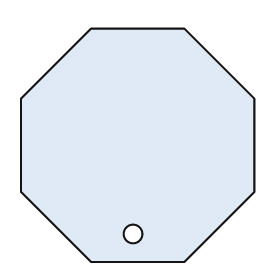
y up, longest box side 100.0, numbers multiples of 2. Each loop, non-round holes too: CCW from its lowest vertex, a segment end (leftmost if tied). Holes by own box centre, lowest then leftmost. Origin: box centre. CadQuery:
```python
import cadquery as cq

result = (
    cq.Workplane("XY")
    .moveTo(-20.0, -50.0)
    .lineTo(20.0, -50.0)
    .lineTo(50.0, -20.0)
    .lineTo(50.0, 20.0)
    .lineTo(20.0, 50.0)
    .lineTo(-20.0, 50.0)
    .lineTo(-50.0, 20.0)
    .lineTo(-50.0, -20.0)
    .close()
    .moveTo(-2.0, -38.0)
    .circle(4.0)
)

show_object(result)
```